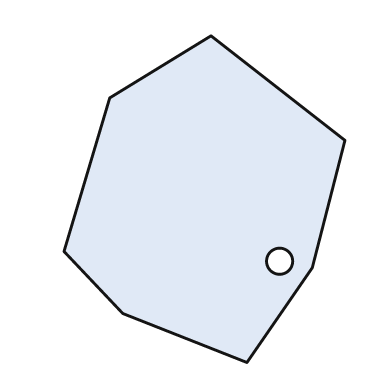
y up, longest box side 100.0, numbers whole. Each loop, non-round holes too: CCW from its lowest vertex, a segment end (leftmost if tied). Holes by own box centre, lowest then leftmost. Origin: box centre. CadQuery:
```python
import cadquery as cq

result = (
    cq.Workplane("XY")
    .moveTo(13.0, -50.0)
    .lineTo(33.0, -21.0)
    .lineTo(43.0, 18.0)
    .lineTo(2.0, 50.0)
    .lineTo(-29.0, 31.0)
    .lineTo(-43.0, -16.0)
    .lineTo(-25.0, -35.0)
    .close()
    .moveTo(23.0, -19.0)
    .circle(4.0)
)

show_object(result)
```